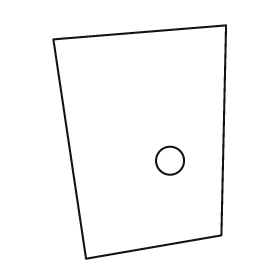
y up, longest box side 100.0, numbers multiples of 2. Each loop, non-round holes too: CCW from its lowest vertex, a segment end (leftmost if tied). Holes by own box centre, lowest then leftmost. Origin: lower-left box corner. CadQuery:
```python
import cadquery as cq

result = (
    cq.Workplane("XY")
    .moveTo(14.0, 0.0)
    .lineTo(72.0, 10.0)
    .lineTo(74.0, 100.0)
    .lineTo(0.0, 94.0)
    .close()
    .moveTo(50.0, 42.0)
    .circle(6.0)
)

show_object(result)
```